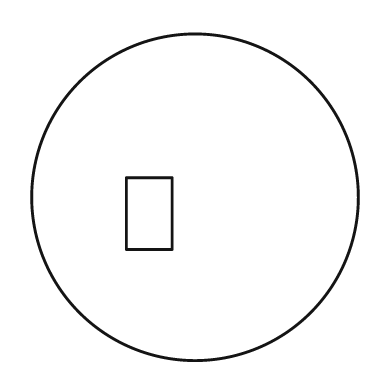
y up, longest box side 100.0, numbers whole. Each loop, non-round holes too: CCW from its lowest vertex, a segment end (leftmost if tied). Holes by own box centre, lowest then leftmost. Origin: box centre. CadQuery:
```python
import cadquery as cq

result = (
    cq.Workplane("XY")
    .moveTo(0.0, 0.0)
    .circle(50.0)
    .moveTo(-21.0, -16.0)
    .lineTo(-7.0, -16.0)
    .lineTo(-7.0, 6.0)
    .lineTo(-21.0, 6.0)
    .close()
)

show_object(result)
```